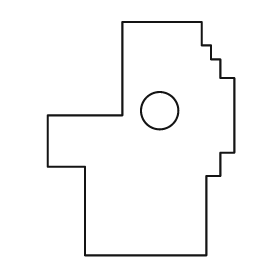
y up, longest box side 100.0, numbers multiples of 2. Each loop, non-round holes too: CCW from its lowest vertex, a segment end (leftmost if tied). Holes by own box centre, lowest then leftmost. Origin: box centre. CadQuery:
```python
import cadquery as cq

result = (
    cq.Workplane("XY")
    .moveTo(-24.0, -50.0)
    .lineTo(28.0, -50.0)
    .lineTo(28.0, -16.0)
    .lineTo(34.0, -16.0)
    .lineTo(34.0, -6.0)
    .lineTo(40.0, -6.0)
    .lineTo(40.0, 26.0)
    .lineTo(34.0, 26.0)
    .lineTo(34.0, 34.0)
    .lineTo(30.0, 34.0)
    .lineTo(30.0, 40.0)
    .lineTo(26.0, 40.0)
    .lineTo(26.0, 50.0)
    .lineTo(-8.0, 50.0)
    .lineTo(-8.0, 10.0)
    .lineTo(-40.0, 10.0)
    .lineTo(-40.0, -12.0)
    .lineTo(-24.0, -12.0)
    .close()
    .moveTo(8.0, 12.0)
    .circle(8.0)
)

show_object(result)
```